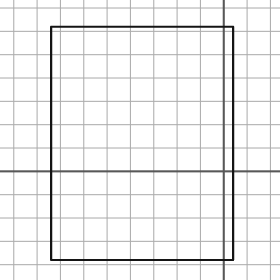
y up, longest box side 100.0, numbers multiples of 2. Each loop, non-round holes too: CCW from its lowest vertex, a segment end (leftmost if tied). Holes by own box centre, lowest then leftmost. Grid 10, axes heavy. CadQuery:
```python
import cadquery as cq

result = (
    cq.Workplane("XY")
    .moveTo(-74.0, -38.0)
    .lineTo(4.0, -38.0)
    .lineTo(4.0, 62.0)
    .lineTo(-74.0, 62.0)
    .close()
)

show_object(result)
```